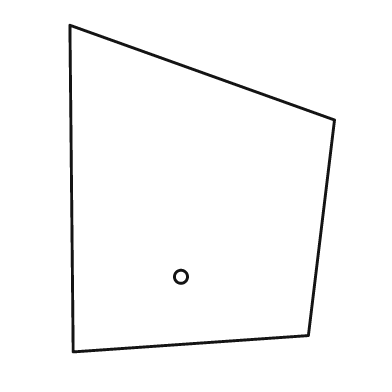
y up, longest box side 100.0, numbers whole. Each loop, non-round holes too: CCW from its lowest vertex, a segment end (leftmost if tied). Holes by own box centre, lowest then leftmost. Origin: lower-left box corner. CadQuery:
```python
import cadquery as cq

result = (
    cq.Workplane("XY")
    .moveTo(1.0, 0.0)
    .lineTo(73.0, 5.0)
    .lineTo(81.0, 71.0)
    .lineTo(0.0, 100.0)
    .close()
    .moveTo(34.0, 23.0)
    .circle(2.0)
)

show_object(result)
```